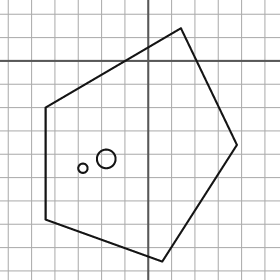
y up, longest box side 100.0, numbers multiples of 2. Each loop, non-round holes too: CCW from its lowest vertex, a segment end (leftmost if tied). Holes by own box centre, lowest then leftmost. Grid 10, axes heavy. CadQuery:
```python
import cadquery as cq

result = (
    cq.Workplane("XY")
    .moveTo(6.0, -86.0)
    .lineTo(38.0, -36.0)
    .lineTo(14.0, 14.0)
    .lineTo(-44.0, -20.0)
    .lineTo(-44.0, -68.0)
    .close()
    .moveTo(-28.0, -46.0)
    .circle(2.0)
    .moveTo(-18.0, -42.0)
    .circle(4.0)
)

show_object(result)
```